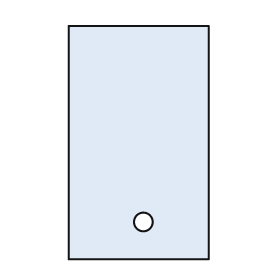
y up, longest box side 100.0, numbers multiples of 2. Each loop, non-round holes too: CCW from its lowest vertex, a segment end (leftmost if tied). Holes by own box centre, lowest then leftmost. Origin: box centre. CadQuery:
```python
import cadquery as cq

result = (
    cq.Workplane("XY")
    .moveTo(-30.0, -50.0)
    .lineTo(30.0, -50.0)
    .lineTo(30.0, 50.0)
    .lineTo(-30.0, 50.0)
    .close()
    .moveTo(2.0, -34.0)
    .circle(4.0)
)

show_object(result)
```